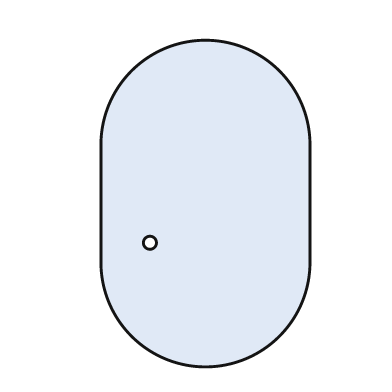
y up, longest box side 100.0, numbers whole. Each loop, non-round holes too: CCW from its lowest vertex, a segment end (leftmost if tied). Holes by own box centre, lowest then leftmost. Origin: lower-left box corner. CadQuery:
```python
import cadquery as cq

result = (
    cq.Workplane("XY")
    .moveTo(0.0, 32.0)
    .threePointArc((32.0, 0.0), (64.0, 32.0))
    .lineTo(64.0, 68.0)
    .threePointArc((32.0, 100.0), (0.0, 68.0))
    .close()
    .moveTo(15.0, 38.0)
    .circle(2.0)
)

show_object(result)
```